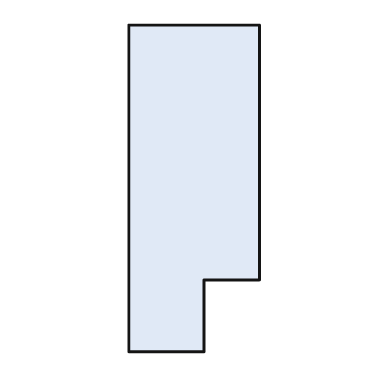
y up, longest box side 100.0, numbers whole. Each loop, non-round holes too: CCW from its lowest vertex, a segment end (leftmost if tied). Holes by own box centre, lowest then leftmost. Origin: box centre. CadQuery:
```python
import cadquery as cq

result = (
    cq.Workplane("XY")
    .moveTo(-20.0, -50.0)
    .lineTo(3.0, -50.0)
    .lineTo(3.0, -28.0)
    .lineTo(20.0, -28.0)
    .lineTo(20.0, 50.0)
    .lineTo(-20.0, 50.0)
    .close()
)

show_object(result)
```